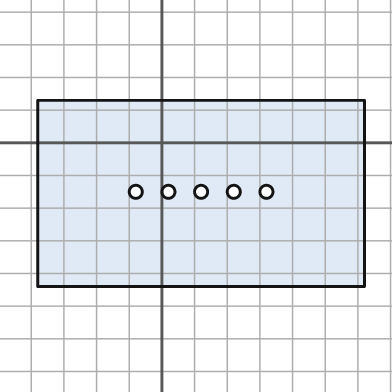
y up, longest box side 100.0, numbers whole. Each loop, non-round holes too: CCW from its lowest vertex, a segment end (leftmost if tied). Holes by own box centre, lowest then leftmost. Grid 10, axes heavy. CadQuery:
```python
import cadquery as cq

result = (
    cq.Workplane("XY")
    .moveTo(-38.0, -44.0)
    .lineTo(62.0, -44.0)
    .lineTo(62.0, 13.0)
    .lineTo(-38.0, 13.0)
    .close()
    .moveTo(-8.0, -15.0)
    .circle(2.0)
    .moveTo(2.0, -15.0)
    .circle(2.0)
    .moveTo(12.0, -15.0)
    .circle(2.0)
    .moveTo(22.0, -15.0)
    .circle(2.0)
    .moveTo(32.0, -15.0)
    .circle(2.0)
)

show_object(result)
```